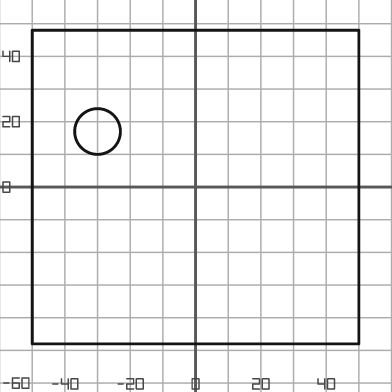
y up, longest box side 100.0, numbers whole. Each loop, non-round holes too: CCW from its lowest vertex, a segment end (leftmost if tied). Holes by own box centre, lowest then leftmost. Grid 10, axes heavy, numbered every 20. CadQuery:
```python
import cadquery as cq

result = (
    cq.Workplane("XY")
    .moveTo(-50.0, -48.0)
    .lineTo(50.0, -48.0)
    .lineTo(50.0, 48.0)
    .lineTo(-50.0, 48.0)
    .close()
    .moveTo(-30.0, 17.0)
    .circle(7.0)
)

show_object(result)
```